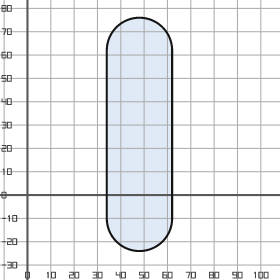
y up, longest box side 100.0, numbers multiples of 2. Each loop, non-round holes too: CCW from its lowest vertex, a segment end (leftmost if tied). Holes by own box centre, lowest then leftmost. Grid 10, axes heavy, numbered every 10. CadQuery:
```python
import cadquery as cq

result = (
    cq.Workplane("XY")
    .moveTo(34.0, -10.0)
    .threePointArc((48.0, -24.0), (62.0, -10.0))
    .lineTo(62.0, 62.0)
    .threePointArc((48.0, 76.0), (34.0, 62.0))
    .close()
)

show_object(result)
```